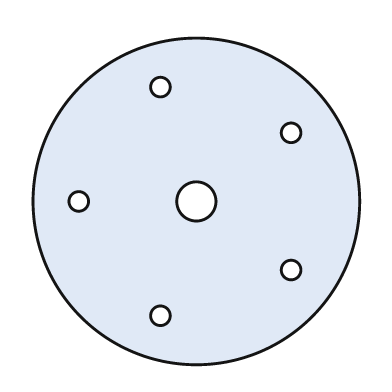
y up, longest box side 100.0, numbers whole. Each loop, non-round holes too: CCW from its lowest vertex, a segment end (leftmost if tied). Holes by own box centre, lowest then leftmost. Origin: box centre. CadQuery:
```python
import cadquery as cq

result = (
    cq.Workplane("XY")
    .moveTo(0.0, 0.0)
    .circle(50.0)
    .moveTo(-11.0, -35.0)
    .circle(3.0)
    .moveTo(29.0, -21.0)
    .circle(3.0)
    .moveTo(-36.0, 0.0)
    .circle(3.0)
    .moveTo(0.0, 0.0)
    .circle(6.0)
    .moveTo(29.0, 21.0)
    .circle(3.0)
    .moveTo(-11.0, 35.0)
    .circle(3.0)
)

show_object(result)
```